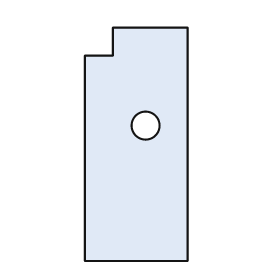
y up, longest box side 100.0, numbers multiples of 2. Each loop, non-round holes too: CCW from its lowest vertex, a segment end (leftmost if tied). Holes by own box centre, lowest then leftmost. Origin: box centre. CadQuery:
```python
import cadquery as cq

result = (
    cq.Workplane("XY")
    .moveTo(-22.0, -50.0)
    .lineTo(22.0, -50.0)
    .lineTo(22.0, 50.0)
    .lineTo(-10.0, 50.0)
    .lineTo(-10.0, 38.0)
    .lineTo(-22.0, 38.0)
    .close()
    .moveTo(4.0, 8.0)
    .circle(6.0)
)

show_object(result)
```